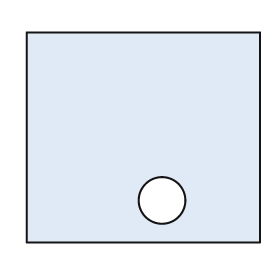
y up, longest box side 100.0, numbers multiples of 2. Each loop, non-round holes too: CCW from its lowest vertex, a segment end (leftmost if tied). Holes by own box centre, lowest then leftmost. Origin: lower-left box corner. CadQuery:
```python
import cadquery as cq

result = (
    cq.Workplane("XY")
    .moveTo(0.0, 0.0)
    .lineTo(100.0, 0.0)
    .lineTo(100.0, 90.0)
    .lineTo(0.0, 90.0)
    .close()
    .moveTo(58.0, 18.0)
    .circle(10.0)
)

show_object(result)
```